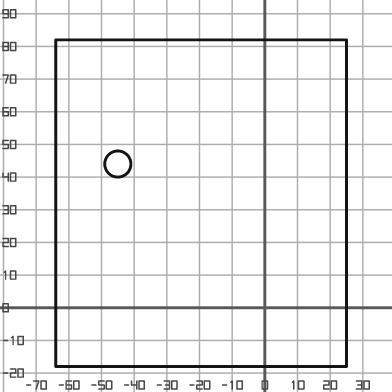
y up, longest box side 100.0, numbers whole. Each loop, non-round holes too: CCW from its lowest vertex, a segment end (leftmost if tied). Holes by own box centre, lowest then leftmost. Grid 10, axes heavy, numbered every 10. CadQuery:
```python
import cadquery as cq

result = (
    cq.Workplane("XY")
    .moveTo(-64.0, -18.0)
    .lineTo(25.0, -18.0)
    .lineTo(25.0, 82.0)
    .lineTo(-64.0, 82.0)
    .close()
    .moveTo(-45.0, 44.0)
    .circle(4.0)
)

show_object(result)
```